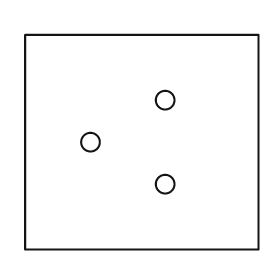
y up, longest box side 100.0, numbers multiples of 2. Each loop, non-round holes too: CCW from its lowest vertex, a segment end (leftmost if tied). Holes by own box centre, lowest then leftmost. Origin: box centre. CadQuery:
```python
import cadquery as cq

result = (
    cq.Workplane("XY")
    .moveTo(-50.0, -46.0)
    .lineTo(50.0, -46.0)
    .lineTo(50.0, 46.0)
    .lineTo(-50.0, 46.0)
    .close()
    .moveTo(10.0, -18.0)
    .circle(4.0)
    .moveTo(-22.0, 0.0)
    .circle(4.0)
    .moveTo(10.0, 18.0)
    .circle(4.0)
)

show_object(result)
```